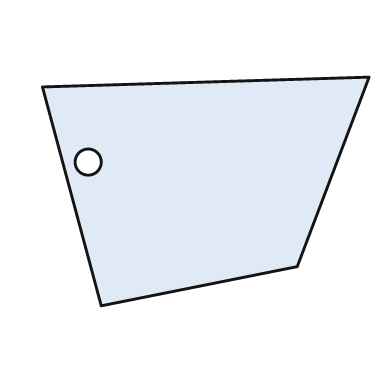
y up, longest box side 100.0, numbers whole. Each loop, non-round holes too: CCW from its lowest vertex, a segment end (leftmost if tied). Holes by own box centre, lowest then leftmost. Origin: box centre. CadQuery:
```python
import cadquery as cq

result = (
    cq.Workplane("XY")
    .moveTo(-32.0, -35.0)
    .lineTo(28.0, -23.0)
    .lineTo(50.0, 35.0)
    .lineTo(-50.0, 32.0)
    .close()
    .moveTo(-36.0, 9.0)
    .circle(4.0)
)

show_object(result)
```